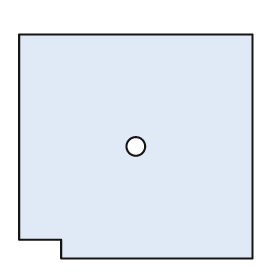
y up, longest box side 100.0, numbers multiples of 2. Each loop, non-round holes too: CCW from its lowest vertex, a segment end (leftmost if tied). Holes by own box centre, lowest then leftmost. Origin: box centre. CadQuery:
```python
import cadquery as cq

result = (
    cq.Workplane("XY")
    .moveTo(-32.0, -48.0)
    .lineTo(50.0, -48.0)
    .lineTo(50.0, 48.0)
    .lineTo(-50.0, 48.0)
    .lineTo(-50.0, -40.0)
    .lineTo(-32.0, -40.0)
    .close()
    .moveTo(0.0, 0.0)
    .circle(4.0)
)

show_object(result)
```